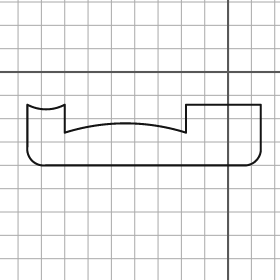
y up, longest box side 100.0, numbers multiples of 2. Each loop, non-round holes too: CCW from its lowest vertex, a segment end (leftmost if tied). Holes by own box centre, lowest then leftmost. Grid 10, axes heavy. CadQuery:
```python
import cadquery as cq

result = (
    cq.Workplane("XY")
    .moveTo(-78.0, -40.0)
    .lineTo(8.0, -40.0)
    .threePointArc((12.0, -38.0), (14.0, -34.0))
    .lineTo(14.0, -14.0)
    .lineTo(-18.0, -14.0)
    .lineTo(-18.0, -26.0)
    .threePointArc((-44.0, -22.0), (-70.0, -26.0))
    .lineTo(-70.0, -14.0)
    .threePointArc((-78.0, -16.0), (-86.0, -14.0))
    .lineTo(-86.0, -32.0)
    .threePointArc((-84.0, -38.0), (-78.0, -40.0))
    .close()
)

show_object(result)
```